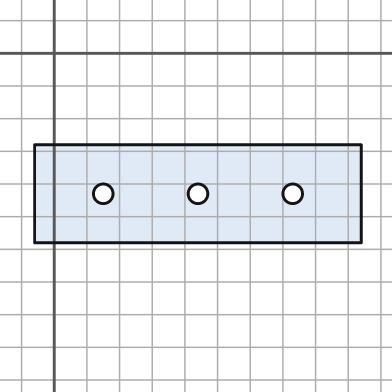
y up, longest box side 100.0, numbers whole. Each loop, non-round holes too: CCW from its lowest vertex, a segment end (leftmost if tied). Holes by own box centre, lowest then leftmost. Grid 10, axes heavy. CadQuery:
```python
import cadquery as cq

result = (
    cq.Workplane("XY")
    .moveTo(-6.0, -58.0)
    .lineTo(94.0, -58.0)
    .lineTo(94.0, -28.0)
    .lineTo(-6.0, -28.0)
    .close()
    .moveTo(15.0, -43.0)
    .circle(3.0)
    .moveTo(44.0, -43.0)
    .circle(3.0)
    .moveTo(73.0, -43.0)
    .circle(3.0)
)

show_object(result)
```